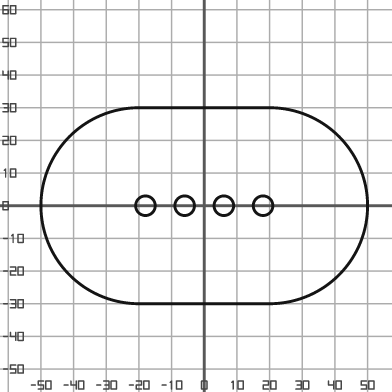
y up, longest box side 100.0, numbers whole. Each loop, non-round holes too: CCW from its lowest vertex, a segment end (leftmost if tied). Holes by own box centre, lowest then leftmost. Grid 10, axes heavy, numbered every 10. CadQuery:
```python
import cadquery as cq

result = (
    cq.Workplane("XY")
    .moveTo(-20.0, -30.0)
    .lineTo(20.0, -30.0)
    .threePointArc((50.0, 0.0), (20.0, 30.0))
    .lineTo(-20.0, 30.0)
    .threePointArc((-50.0, 0.0), (-20.0, -30.0))
    .close()
    .moveTo(-18.0, 0.0)
    .circle(3.0)
    .moveTo(-6.0, 0.0)
    .circle(3.0)
    .moveTo(6.0, 0.0)
    .circle(3.0)
    .moveTo(18.0, 0.0)
    .circle(3.0)
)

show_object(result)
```